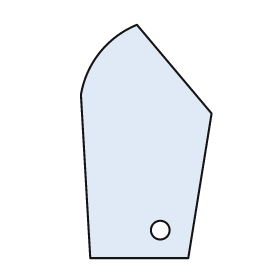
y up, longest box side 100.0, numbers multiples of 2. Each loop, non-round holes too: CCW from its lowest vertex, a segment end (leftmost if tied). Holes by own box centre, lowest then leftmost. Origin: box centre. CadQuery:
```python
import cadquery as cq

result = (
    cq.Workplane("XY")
    .moveTo(-24.0, -50.0)
    .lineTo(18.0, -50.0)
    .lineTo(28.0, 12.0)
    .lineTo(-4.0, 50.0)
    .threePointArc((-20.0, 38.0), (-28.0, 20.0))
    .close()
    .moveTo(6.0, -38.0)
    .circle(4.0)
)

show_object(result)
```